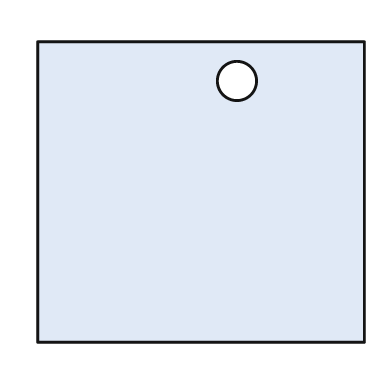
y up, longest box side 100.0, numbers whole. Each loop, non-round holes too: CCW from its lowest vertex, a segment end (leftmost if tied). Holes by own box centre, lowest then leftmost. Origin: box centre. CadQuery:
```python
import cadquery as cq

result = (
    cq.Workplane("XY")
    .moveTo(-50.0, -46.0)
    .lineTo(50.0, -46.0)
    .lineTo(50.0, 46.0)
    .lineTo(-50.0, 46.0)
    .close()
    .moveTo(11.0, 34.0)
    .circle(6.0)
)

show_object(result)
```